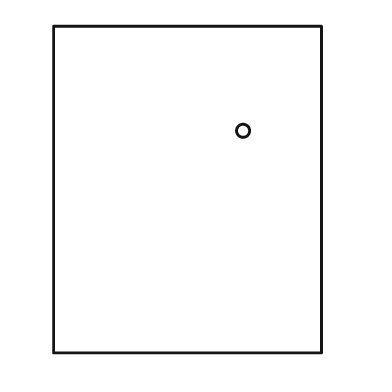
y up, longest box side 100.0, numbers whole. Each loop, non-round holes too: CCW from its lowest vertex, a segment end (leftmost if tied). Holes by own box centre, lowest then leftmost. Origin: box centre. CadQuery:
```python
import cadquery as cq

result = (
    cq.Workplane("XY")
    .moveTo(-41.0, -50.0)
    .lineTo(41.0, -50.0)
    .lineTo(41.0, 50.0)
    .lineTo(-41.0, 50.0)
    .close()
    .moveTo(17.0, 18.0)
    .circle(2.0)
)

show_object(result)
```